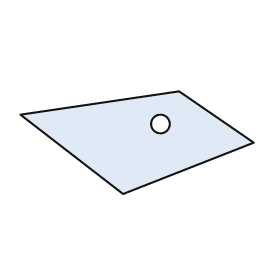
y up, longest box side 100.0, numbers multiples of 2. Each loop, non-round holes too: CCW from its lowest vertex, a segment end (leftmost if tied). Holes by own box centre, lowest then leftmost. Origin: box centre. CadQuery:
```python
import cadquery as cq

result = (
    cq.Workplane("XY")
    .moveTo(-6.0, -22.0)
    .lineTo(50.0, 0.0)
    .lineTo(18.0, 22.0)
    .lineTo(-50.0, 12.0)
    .close()
    .moveTo(10.0, 8.0)
    .circle(4.0)
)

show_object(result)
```